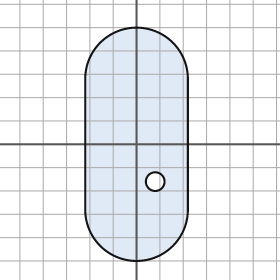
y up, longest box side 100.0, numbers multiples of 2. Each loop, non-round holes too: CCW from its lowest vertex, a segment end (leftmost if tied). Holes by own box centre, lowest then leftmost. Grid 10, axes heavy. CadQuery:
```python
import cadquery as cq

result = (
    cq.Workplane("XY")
    .moveTo(-22.0, -28.0)
    .threePointArc((0.0, -50.0), (22.0, -28.0))
    .lineTo(22.0, 28.0)
    .threePointArc((0.0, 50.0), (-22.0, 28.0))
    .close()
    .moveTo(8.0, -16.0)
    .circle(4.0)
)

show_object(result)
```